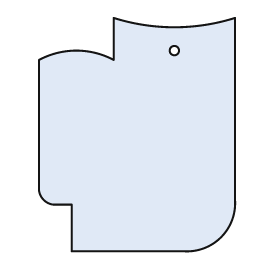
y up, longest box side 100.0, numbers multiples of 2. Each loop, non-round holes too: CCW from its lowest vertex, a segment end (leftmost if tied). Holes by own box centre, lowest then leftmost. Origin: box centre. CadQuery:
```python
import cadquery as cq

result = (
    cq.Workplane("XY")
    .moveTo(-28.0, -50.0)
    .lineTo(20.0, -50.0)
    .threePointArc((36.0, -44.0), (42.0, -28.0))
    .lineTo(42.0, 50.0)
    .threePointArc((16.0, 46.0), (-10.0, 50.0))
    .lineTo(-10.0, 32.0)
    .threePointArc((-26.0, 36.0), (-42.0, 32.0))
    .lineTo(-42.0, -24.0)
    .threePointArc((-40.0, -28.0), (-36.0, -30.0))
    .lineTo(-28.0, -30.0)
    .close()
    .moveTo(16.0, 36.0)
    .circle(2.0)
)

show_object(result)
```